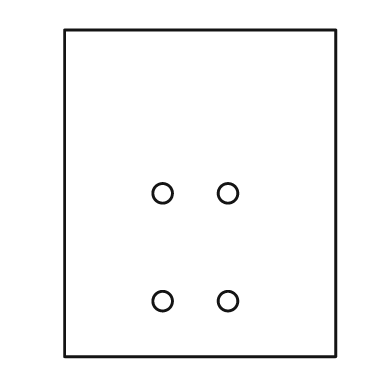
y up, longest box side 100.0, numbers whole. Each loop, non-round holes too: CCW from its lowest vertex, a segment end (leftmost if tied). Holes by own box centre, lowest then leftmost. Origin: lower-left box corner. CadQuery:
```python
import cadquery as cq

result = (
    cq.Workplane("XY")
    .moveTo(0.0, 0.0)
    .lineTo(83.0, 0.0)
    .lineTo(83.0, 100.0)
    .lineTo(0.0, 100.0)
    .close()
    .moveTo(30.0, 17.0)
    .circle(3.0)
    .moveTo(50.0, 17.0)
    .circle(3.0)
    .moveTo(30.0, 50.0)
    .circle(3.0)
    .moveTo(50.0, 50.0)
    .circle(3.0)
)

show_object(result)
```